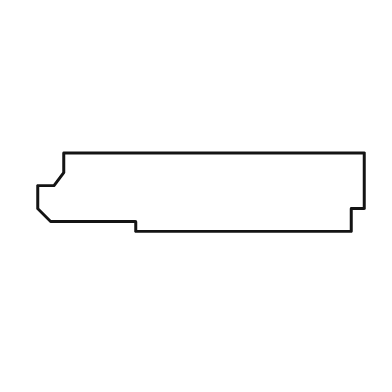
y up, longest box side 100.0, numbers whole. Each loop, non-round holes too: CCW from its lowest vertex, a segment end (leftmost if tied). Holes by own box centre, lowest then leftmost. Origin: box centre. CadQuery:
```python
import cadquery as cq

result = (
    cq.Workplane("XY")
    .moveTo(-20.0, -12.0)
    .lineTo(46.0, -12.0)
    .lineTo(46.0, -5.0)
    .lineTo(50.0, -5.0)
    .lineTo(50.0, 12.0)
    .lineTo(-42.0, 12.0)
    .lineTo(-42.0, 6.0)
    .lineTo(-45.0, 2.0)
    .lineTo(-50.0, 2.0)
    .lineTo(-50.0, -5.0)
    .lineTo(-46.0, -9.0)
    .lineTo(-20.0, -9.0)
    .close()
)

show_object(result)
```